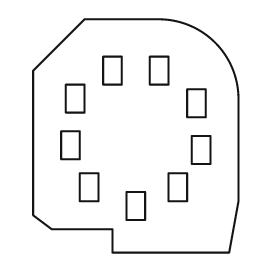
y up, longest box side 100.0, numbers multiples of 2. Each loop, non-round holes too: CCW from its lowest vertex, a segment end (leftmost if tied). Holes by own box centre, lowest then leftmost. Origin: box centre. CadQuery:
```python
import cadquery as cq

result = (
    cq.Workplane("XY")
    .moveTo(-10.0, -50.0)
    .lineTo(40.0, -50.0)
    .lineTo(44.0, -28.0)
    .lineTo(44.0, 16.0)
    .threePointArc((34.0, 40.0), (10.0, 50.0))
    .lineTo(-22.0, 50.0)
    .lineTo(-44.0, 28.0)
    .lineTo(-44.0, -34.0)
    .lineTo(-36.0, -40.0)
    .lineTo(-10.0, -40.0)
    .close()
    .moveTo(-4.0, -36.0)
    .lineTo(4.0, -36.0)
    .lineTo(4.0, -24.0)
    .lineTo(-4.0, -24.0)
    .close()
    .moveTo(-24.0, -28.0)
    .lineTo(-16.0, -28.0)
    .lineTo(-16.0, -16.0)
    .lineTo(-24.0, -16.0)
    .close()
    .moveTo(14.0, -28.0)
    .lineTo(22.0, -28.0)
    .lineTo(22.0, -16.0)
    .lineTo(14.0, -16.0)
    .close()
    .moveTo(24.0, -12.0)
    .lineTo(32.0, -12.0)
    .lineTo(32.0, 0.0)
    .lineTo(24.0, 0.0)
    .close()
    .moveTo(-32.0, -10.0)
    .lineTo(-24.0, -10.0)
    .lineTo(-24.0, 2.0)
    .lineTo(-32.0, 2.0)
    .close()
    .moveTo(22.0, 8.0)
    .lineTo(30.0, 8.0)
    .lineTo(30.0, 20.0)
    .lineTo(22.0, 20.0)
    .close()
    .moveTo(-30.0, 10.0)
    .lineTo(-22.0, 10.0)
    .lineTo(-22.0, 22.0)
    .lineTo(-30.0, 22.0)
    .close()
    .moveTo(-14.0, 22.0)
    .lineTo(-6.0, 22.0)
    .lineTo(-6.0, 34.0)
    .lineTo(-14.0, 34.0)
    .close()
    .moveTo(6.0, 22.0)
    .lineTo(14.0, 22.0)
    .lineTo(14.0, 34.0)
    .lineTo(6.0, 34.0)
    .close()
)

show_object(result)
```